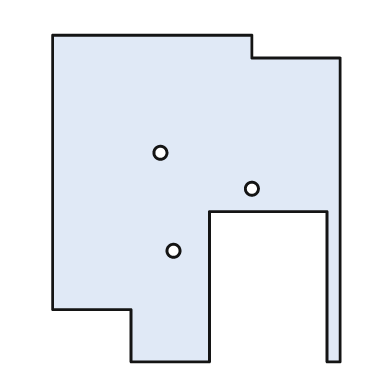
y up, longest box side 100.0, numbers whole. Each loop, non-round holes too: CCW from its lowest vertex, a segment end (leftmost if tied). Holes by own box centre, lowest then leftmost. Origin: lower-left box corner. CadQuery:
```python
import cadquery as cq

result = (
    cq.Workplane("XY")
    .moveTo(24.0, 0.0)
    .lineTo(48.0, 0.0)
    .lineTo(48.0, 46.0)
    .lineTo(84.0, 46.0)
    .lineTo(84.0, 0.0)
    .lineTo(88.0, 0.0)
    .lineTo(88.0, 93.0)
    .lineTo(61.0, 93.0)
    .lineTo(61.0, 100.0)
    .lineTo(0.0, 100.0)
    .lineTo(0.0, 16.0)
    .lineTo(24.0, 16.0)
    .close()
    .moveTo(37.0, 34.0)
    .circle(2.0)
    .moveTo(61.0, 53.0)
    .circle(2.0)
    .moveTo(33.0, 64.0)
    .circle(2.0)
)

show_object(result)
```